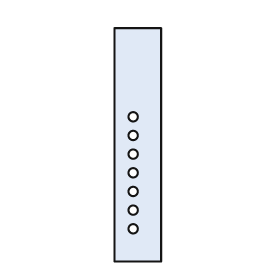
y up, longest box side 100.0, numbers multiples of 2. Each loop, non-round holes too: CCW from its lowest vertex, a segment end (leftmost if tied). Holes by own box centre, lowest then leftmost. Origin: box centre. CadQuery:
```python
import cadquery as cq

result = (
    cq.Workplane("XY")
    .moveTo(-10.0, -50.0)
    .lineTo(10.0, -50.0)
    .lineTo(10.0, 50.0)
    .lineTo(-10.0, 50.0)
    .close()
    .moveTo(-2.0, -36.0)
    .circle(2.0)
    .moveTo(-2.0, -28.0)
    .circle(2.0)
    .moveTo(-2.0, -20.0)
    .circle(2.0)
    .moveTo(-2.0, -12.0)
    .circle(2.0)
    .moveTo(-2.0, -4.0)
    .circle(2.0)
    .moveTo(-2.0, 4.0)
    .circle(2.0)
    .moveTo(-2.0, 12.0)
    .circle(2.0)
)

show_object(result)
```